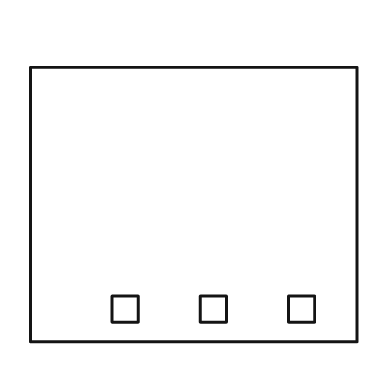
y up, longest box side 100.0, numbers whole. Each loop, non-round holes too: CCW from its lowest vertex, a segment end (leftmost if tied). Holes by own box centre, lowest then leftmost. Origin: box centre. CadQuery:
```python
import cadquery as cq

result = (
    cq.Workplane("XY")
    .moveTo(-50.0, -42.0)
    .lineTo(50.0, -42.0)
    .lineTo(50.0, 42.0)
    .lineTo(-50.0, 42.0)
    .close()
    .moveTo(-25.0, -36.0)
    .lineTo(-17.0, -36.0)
    .lineTo(-17.0, -28.0)
    .lineTo(-25.0, -28.0)
    .close()
    .moveTo(2.0, -36.0)
    .lineTo(10.0, -36.0)
    .lineTo(10.0, -28.0)
    .lineTo(2.0, -28.0)
    .close()
    .moveTo(29.0, -36.0)
    .lineTo(37.0, -36.0)
    .lineTo(37.0, -28.0)
    .lineTo(29.0, -28.0)
    .close()
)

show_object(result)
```